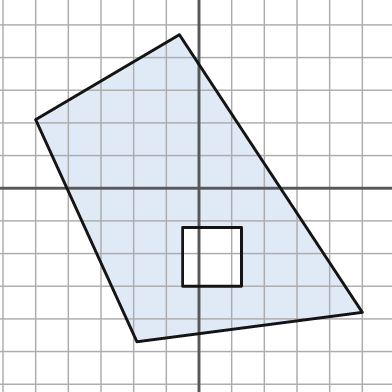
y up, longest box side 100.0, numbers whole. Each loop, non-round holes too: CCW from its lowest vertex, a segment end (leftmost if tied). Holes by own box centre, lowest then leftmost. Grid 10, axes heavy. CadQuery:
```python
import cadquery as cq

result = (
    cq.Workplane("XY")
    .moveTo(-19.0, -47.0)
    .lineTo(50.0, -38.0)
    .lineTo(-6.0, 47.0)
    .lineTo(-50.0, 21.0)
    .close()
    .moveTo(-5.0, -30.0)
    .lineTo(13.0, -30.0)
    .lineTo(13.0, -12.0)
    .lineTo(-5.0, -12.0)
    .close()
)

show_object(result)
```